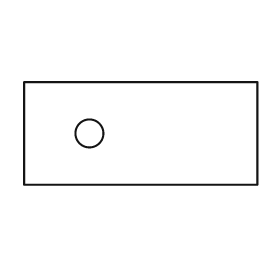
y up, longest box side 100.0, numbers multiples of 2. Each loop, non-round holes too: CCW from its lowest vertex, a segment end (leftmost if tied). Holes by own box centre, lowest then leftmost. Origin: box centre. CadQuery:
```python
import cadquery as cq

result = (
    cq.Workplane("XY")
    .moveTo(-50.0, -22.0)
    .lineTo(50.0, -22.0)
    .lineTo(50.0, 22.0)
    .lineTo(-50.0, 22.0)
    .close()
    .moveTo(-22.0, 0.0)
    .circle(6.0)
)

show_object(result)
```